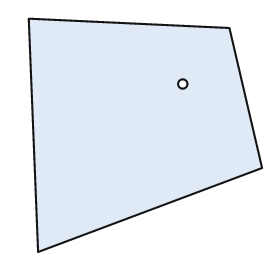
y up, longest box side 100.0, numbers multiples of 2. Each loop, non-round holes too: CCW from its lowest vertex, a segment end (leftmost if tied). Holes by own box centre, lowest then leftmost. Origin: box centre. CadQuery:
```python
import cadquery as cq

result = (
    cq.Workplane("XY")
    .moveTo(-46.0, -50.0)
    .lineTo(50.0, -14.0)
    .lineTo(36.0, 46.0)
    .lineTo(-50.0, 50.0)
    .close()
    .moveTo(16.0, 22.0)
    .circle(2.0)
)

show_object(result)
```